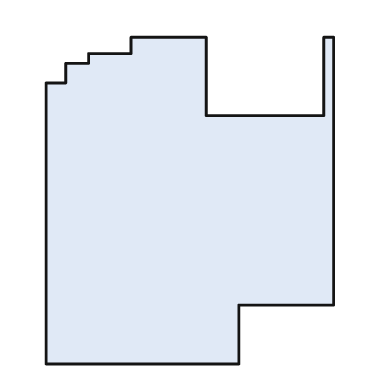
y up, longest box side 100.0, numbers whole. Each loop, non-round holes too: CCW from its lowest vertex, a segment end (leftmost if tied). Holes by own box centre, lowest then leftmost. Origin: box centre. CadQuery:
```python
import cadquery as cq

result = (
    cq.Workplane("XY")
    .moveTo(-44.0, -50.0)
    .lineTo(15.0, -50.0)
    .lineTo(15.0, -32.0)
    .lineTo(44.0, -32.0)
    .lineTo(44.0, 50.0)
    .lineTo(41.0, 50.0)
    .lineTo(41.0, 26.0)
    .lineTo(5.0, 26.0)
    .lineTo(5.0, 50.0)
    .lineTo(-18.0, 50.0)
    .lineTo(-18.0, 45.0)
    .lineTo(-31.0, 45.0)
    .lineTo(-31.0, 42.0)
    .lineTo(-38.0, 42.0)
    .lineTo(-38.0, 36.0)
    .lineTo(-44.0, 36.0)
    .close()
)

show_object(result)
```